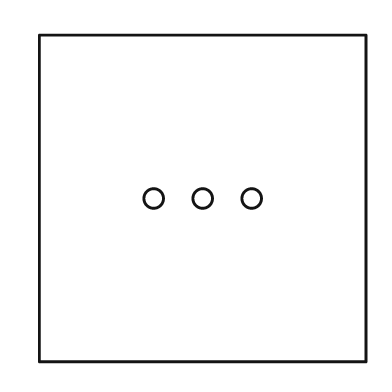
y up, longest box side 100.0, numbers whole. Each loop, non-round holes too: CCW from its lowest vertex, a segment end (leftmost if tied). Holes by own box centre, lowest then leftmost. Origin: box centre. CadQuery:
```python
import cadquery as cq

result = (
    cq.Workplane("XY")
    .moveTo(-50.0, -50.0)
    .lineTo(50.0, -50.0)
    .lineTo(50.0, 50.0)
    .lineTo(-50.0, 50.0)
    .close()
    .moveTo(-15.0, 0.0)
    .circle(3.0)
    .moveTo(0.0, 0.0)
    .circle(3.0)
    .moveTo(15.0, 0.0)
    .circle(3.0)
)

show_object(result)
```